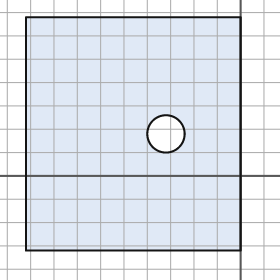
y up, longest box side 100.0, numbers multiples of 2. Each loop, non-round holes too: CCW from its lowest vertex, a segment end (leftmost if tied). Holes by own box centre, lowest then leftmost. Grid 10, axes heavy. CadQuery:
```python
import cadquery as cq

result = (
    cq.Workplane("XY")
    .moveTo(-92.0, -32.0)
    .lineTo(0.0, -32.0)
    .lineTo(0.0, 68.0)
    .lineTo(-92.0, 68.0)
    .close()
    .moveTo(-32.0, 18.0)
    .circle(8.0)
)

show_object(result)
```